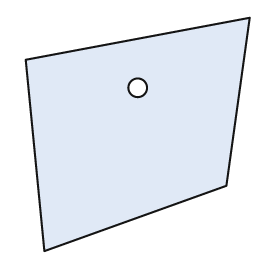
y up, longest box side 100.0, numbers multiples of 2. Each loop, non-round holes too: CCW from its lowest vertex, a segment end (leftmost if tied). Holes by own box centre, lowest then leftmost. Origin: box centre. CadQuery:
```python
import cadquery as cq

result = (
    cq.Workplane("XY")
    .moveTo(-40.0, -50.0)
    .lineTo(38.0, -22.0)
    .lineTo(48.0, 50.0)
    .lineTo(-48.0, 32.0)
    .close()
    .moveTo(0.0, 20.0)
    .circle(4.0)
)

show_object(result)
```